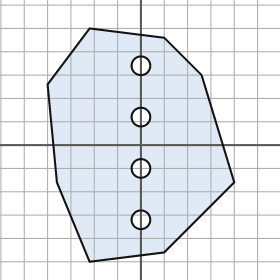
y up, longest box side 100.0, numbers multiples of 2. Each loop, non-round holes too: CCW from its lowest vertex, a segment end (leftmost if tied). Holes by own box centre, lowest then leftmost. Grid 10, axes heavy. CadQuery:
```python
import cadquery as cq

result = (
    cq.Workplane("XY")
    .moveTo(-22.0, -50.0)
    .lineTo(10.0, -46.0)
    .lineTo(40.0, -16.0)
    .lineTo(26.0, 30.0)
    .lineTo(10.0, 46.0)
    .lineTo(-22.0, 50.0)
    .lineTo(-40.0, 26.0)
    .lineTo(-36.0, -16.0)
    .close()
    .moveTo(0.0, -32.0)
    .circle(4.0)
    .moveTo(0.0, -10.0)
    .circle(4.0)
    .moveTo(0.0, 12.0)
    .circle(4.0)
    .moveTo(0.0, 34.0)
    .circle(4.0)
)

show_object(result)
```